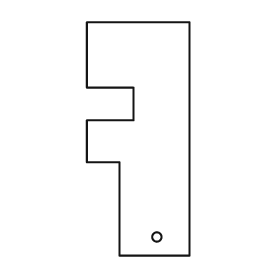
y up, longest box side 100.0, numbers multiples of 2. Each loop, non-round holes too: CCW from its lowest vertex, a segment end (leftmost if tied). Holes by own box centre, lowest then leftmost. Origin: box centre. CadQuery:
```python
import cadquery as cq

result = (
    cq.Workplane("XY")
    .moveTo(-8.0, -50.0)
    .lineTo(22.0, -50.0)
    .lineTo(22.0, 50.0)
    .lineTo(-22.0, 50.0)
    .lineTo(-22.0, 22.0)
    .lineTo(-2.0, 22.0)
    .lineTo(-2.0, 8.0)
    .lineTo(-22.0, 8.0)
    .lineTo(-22.0, -10.0)
    .lineTo(-8.0, -10.0)
    .close()
    .moveTo(8.0, -42.0)
    .circle(2.0)
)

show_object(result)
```